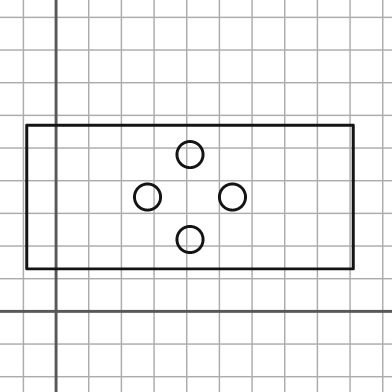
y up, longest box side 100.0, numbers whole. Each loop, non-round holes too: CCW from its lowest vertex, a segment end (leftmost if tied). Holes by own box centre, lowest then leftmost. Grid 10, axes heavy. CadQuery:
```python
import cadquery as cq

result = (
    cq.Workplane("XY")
    .moveTo(-9.0, 13.0)
    .lineTo(91.0, 13.0)
    .lineTo(91.0, 57.0)
    .lineTo(-9.0, 57.0)
    .close()
    .moveTo(41.0, 22.0)
    .circle(4.0)
    .moveTo(28.0, 35.0)
    .circle(4.0)
    .moveTo(54.0, 35.0)
    .circle(4.0)
    .moveTo(41.0, 48.0)
    .circle(4.0)
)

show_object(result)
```